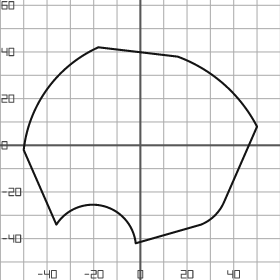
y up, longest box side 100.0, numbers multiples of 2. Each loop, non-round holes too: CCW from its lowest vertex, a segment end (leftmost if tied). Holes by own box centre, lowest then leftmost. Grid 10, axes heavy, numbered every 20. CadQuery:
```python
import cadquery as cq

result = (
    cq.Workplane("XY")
    .moveTo(-2.0, -42.0)
    .lineTo(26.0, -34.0)
    .threePointArc((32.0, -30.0), (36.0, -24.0))
    .lineTo(50.0, 8.0)
    .threePointArc((36.0, 26.0), (16.0, 38.0))
    .lineTo(-18.0, 42.0)
    .threePointArc((-40.0, 24.0), (-50.0, -2.0))
    .lineTo(-36.0, -34.0)
    .threePointArc((-16.0, -26.0), (-2.0, -42.0))
    .close()
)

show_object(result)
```